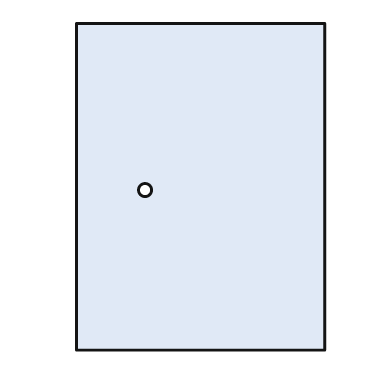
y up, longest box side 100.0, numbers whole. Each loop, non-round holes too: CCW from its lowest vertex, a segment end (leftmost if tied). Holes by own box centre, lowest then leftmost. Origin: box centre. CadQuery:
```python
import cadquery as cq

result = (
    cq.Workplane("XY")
    .moveTo(-38.0, -50.0)
    .lineTo(38.0, -50.0)
    .lineTo(38.0, 50.0)
    .lineTo(-38.0, 50.0)
    .close()
    .moveTo(-17.0, -1.0)
    .circle(2.0)
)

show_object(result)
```